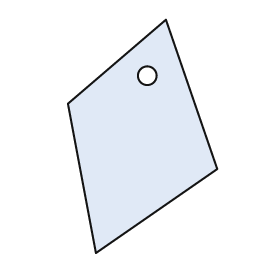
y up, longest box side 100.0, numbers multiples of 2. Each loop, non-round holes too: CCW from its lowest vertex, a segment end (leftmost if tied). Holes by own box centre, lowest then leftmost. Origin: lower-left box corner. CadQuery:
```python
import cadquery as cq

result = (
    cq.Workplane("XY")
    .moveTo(12.0, 0.0)
    .lineTo(64.0, 36.0)
    .lineTo(42.0, 100.0)
    .lineTo(0.0, 64.0)
    .close()
    .moveTo(34.0, 76.0)
    .circle(4.0)
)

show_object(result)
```